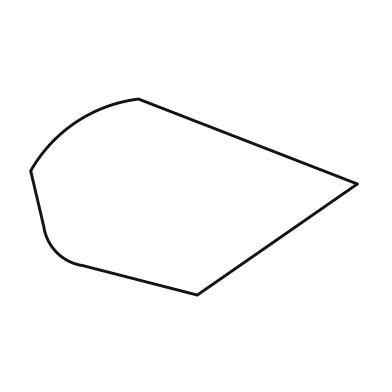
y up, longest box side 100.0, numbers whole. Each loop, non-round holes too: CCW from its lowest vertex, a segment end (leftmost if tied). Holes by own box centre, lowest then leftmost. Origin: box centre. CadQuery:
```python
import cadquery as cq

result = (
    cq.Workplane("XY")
    .moveTo(1.0, -30.0)
    .lineTo(50.0, 4.0)
    .lineTo(-17.0, 30.0)
    .threePointArc((-36.0, 23.0), (-50.0, 8.0))
    .lineTo(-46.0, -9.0)
    .threePointArc((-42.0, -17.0), (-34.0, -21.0))
    .close()
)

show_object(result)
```